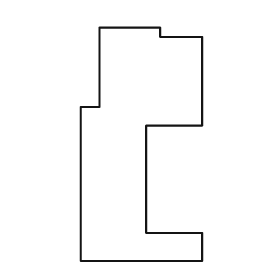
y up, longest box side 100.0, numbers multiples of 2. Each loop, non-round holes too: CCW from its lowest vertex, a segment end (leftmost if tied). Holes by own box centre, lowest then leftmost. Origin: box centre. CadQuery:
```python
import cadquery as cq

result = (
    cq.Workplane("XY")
    .moveTo(-26.0, -50.0)
    .lineTo(26.0, -50.0)
    .lineTo(26.0, -38.0)
    .lineTo(2.0, -38.0)
    .lineTo(2.0, 8.0)
    .lineTo(26.0, 8.0)
    .lineTo(26.0, 46.0)
    .lineTo(8.0, 46.0)
    .lineTo(8.0, 50.0)
    .lineTo(-18.0, 50.0)
    .lineTo(-18.0, 16.0)
    .lineTo(-26.0, 16.0)
    .close()
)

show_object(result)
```